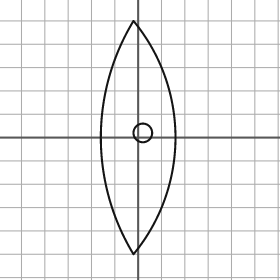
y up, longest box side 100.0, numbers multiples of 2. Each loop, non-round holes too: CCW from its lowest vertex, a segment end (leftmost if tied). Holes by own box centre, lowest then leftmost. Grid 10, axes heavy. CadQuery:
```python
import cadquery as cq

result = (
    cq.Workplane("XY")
    .moveTo(-2.0, -50.0)
    .threePointArc((16.0, 0.0), (-2.0, 50.0))
    .threePointArc((-16.0, 0.0), (-2.0, -50.0))
    .close()
    .moveTo(2.0, 2.0)
    .circle(4.0)
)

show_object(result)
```